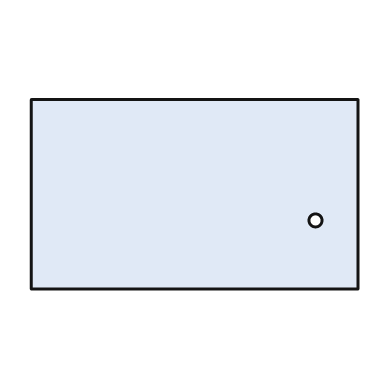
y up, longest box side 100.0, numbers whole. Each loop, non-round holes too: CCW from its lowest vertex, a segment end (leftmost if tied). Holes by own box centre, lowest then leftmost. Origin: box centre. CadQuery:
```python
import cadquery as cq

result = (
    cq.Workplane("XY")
    .moveTo(-50.0, -29.0)
    .lineTo(50.0, -29.0)
    .lineTo(50.0, 29.0)
    .lineTo(-50.0, 29.0)
    .close()
    .moveTo(37.0, -8.0)
    .circle(2.0)
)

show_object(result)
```